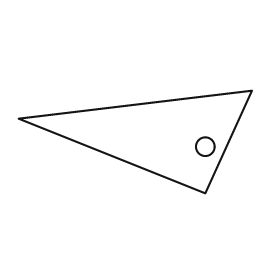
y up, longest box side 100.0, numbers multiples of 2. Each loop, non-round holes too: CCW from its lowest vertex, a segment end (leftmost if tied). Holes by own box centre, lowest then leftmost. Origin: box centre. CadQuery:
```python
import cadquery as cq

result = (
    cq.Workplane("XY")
    .moveTo(30.0, -22.0)
    .lineTo(50.0, 22.0)
    .lineTo(-50.0, 10.0)
    .close()
    .moveTo(30.0, -2.0)
    .circle(4.0)
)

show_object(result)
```